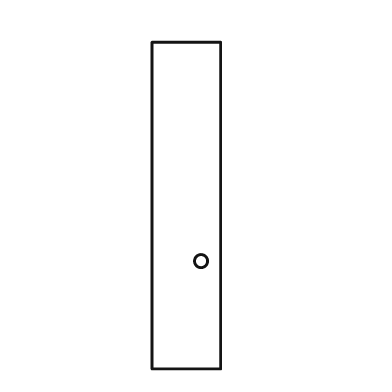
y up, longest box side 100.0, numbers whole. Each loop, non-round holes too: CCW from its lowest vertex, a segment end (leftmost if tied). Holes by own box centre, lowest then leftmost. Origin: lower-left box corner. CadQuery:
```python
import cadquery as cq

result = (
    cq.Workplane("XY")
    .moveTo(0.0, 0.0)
    .lineTo(21.0, 0.0)
    .lineTo(21.0, 100.0)
    .lineTo(0.0, 100.0)
    .close()
    .moveTo(15.0, 33.0)
    .circle(2.0)
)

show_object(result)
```